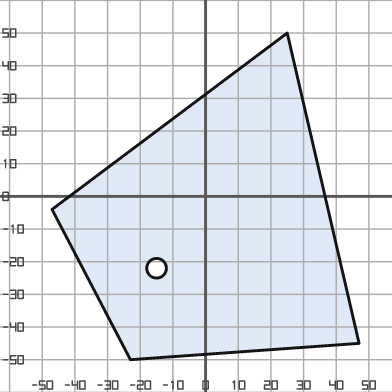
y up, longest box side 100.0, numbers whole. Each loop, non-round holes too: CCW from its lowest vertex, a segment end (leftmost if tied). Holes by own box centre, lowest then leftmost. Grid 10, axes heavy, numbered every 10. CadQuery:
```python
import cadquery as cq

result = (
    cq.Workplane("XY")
    .moveTo(-23.0, -50.0)
    .lineTo(47.0, -45.0)
    .lineTo(25.0, 50.0)
    .lineTo(-47.0, -4.0)
    .close()
    .moveTo(-15.0, -22.0)
    .circle(3.0)
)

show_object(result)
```